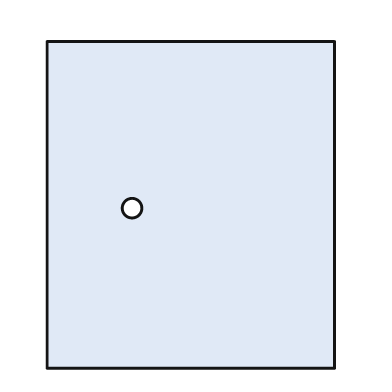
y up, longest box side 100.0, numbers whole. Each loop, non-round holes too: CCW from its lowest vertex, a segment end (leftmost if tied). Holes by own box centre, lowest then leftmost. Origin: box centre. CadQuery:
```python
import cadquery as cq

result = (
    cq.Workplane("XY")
    .moveTo(-44.0, -50.0)
    .lineTo(44.0, -50.0)
    .lineTo(44.0, 50.0)
    .lineTo(-44.0, 50.0)
    .close()
    .moveTo(-18.0, -1.0)
    .circle(3.0)
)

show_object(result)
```